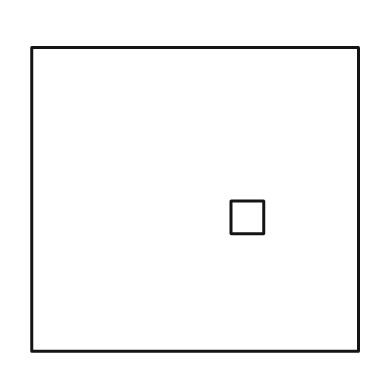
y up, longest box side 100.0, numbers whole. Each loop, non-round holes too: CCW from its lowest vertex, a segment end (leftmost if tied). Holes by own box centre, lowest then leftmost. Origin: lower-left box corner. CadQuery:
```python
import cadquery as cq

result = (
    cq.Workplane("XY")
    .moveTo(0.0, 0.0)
    .lineTo(100.0, 0.0)
    .lineTo(100.0, 93.0)
    .lineTo(0.0, 93.0)
    .close()
    .moveTo(61.0, 36.0)
    .lineTo(71.0, 36.0)
    .lineTo(71.0, 46.0)
    .lineTo(61.0, 46.0)
    .close()
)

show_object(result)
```